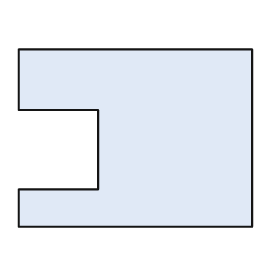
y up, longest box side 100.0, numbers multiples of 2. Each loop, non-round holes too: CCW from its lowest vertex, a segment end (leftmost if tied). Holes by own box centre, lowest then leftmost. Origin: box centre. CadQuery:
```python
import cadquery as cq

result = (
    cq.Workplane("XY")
    .moveTo(-50.0, -38.0)
    .lineTo(50.0, -38.0)
    .lineTo(50.0, 38.0)
    .lineTo(-50.0, 38.0)
    .lineTo(-50.0, 12.0)
    .lineTo(-16.0, 12.0)
    .lineTo(-16.0, -22.0)
    .lineTo(-50.0, -22.0)
    .close()
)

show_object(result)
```